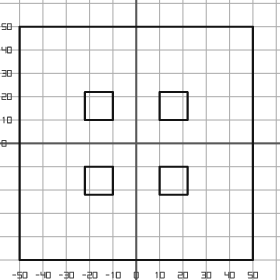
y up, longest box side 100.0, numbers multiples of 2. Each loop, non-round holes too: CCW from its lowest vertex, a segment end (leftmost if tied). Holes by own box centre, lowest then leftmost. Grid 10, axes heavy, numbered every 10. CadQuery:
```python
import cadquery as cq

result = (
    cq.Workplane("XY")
    .moveTo(-50.0, -50.0)
    .lineTo(50.0, -50.0)
    .lineTo(50.0, 50.0)
    .lineTo(-50.0, 50.0)
    .close()
    .moveTo(-22.0, -22.0)
    .lineTo(-10.0, -22.0)
    .lineTo(-10.0, -10.0)
    .lineTo(-22.0, -10.0)
    .close()
    .moveTo(10.0, -22.0)
    .lineTo(22.0, -22.0)
    .lineTo(22.0, -10.0)
    .lineTo(10.0, -10.0)
    .close()
    .moveTo(-22.0, 10.0)
    .lineTo(-10.0, 10.0)
    .lineTo(-10.0, 22.0)
    .lineTo(-22.0, 22.0)
    .close()
    .moveTo(10.0, 10.0)
    .lineTo(22.0, 10.0)
    .lineTo(22.0, 22.0)
    .lineTo(10.0, 22.0)
    .close()
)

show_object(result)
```